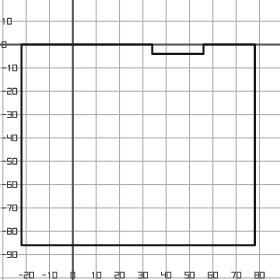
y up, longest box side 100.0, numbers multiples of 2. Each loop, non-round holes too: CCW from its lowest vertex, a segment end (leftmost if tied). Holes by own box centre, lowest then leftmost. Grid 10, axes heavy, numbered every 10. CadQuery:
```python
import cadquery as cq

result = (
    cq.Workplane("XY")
    .moveTo(-22.0, -86.0)
    .lineTo(78.0, -86.0)
    .lineTo(78.0, 0.0)
    .lineTo(56.0, 0.0)
    .lineTo(56.0, -4.0)
    .lineTo(34.0, -4.0)
    .lineTo(34.0, 0.0)
    .lineTo(-22.0, 0.0)
    .close()
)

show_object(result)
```